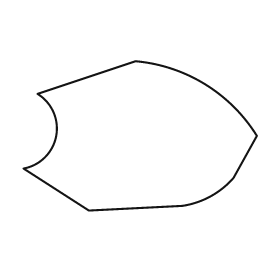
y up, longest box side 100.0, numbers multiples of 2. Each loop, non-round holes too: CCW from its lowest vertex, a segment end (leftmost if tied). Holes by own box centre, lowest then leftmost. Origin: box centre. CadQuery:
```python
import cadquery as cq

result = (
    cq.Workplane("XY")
    .moveTo(-22.0, -32.0)
    .lineTo(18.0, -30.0)
    .threePointArc((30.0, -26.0), (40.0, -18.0))
    .lineTo(50.0, 0.0)
    .threePointArc((28.0, 22.0), (-2.0, 32.0))
    .lineTo(-44.0, 18.0)
    .threePointArc((-36.0, 0.0), (-50.0, -14.0))
    .close()
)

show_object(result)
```